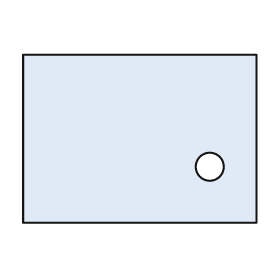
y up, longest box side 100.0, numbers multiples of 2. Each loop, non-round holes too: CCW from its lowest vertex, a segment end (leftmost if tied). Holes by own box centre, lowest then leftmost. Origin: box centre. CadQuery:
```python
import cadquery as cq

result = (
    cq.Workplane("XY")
    .moveTo(-50.0, -36.0)
    .lineTo(50.0, -36.0)
    .lineTo(50.0, 36.0)
    .lineTo(-50.0, 36.0)
    .close()
    .moveTo(30.0, -12.0)
    .circle(6.0)
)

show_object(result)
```